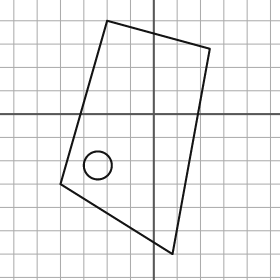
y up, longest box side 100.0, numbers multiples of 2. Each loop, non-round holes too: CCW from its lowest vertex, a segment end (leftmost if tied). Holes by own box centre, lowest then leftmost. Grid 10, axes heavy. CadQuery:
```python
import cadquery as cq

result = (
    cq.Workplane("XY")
    .moveTo(8.0, -60.0)
    .lineTo(24.0, 28.0)
    .lineTo(-20.0, 40.0)
    .lineTo(-40.0, -30.0)
    .close()
    .moveTo(-24.0, -22.0)
    .circle(6.0)
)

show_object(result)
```